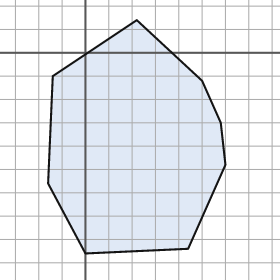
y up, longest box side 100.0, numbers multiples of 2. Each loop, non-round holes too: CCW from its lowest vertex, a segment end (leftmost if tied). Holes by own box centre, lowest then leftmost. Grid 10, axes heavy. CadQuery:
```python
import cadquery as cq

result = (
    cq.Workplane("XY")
    .moveTo(0.0, -86.0)
    .lineTo(44.0, -84.0)
    .lineTo(60.0, -48.0)
    .lineTo(58.0, -30.0)
    .lineTo(50.0, -12.0)
    .lineTo(22.0, 14.0)
    .lineTo(-14.0, -10.0)
    .lineTo(-16.0, -56.0)
    .close()
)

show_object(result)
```